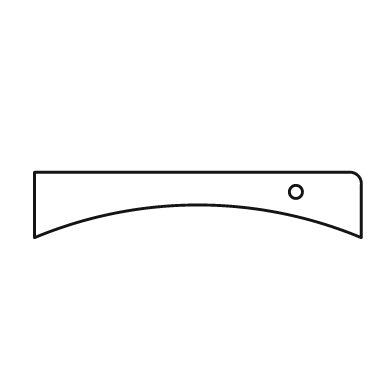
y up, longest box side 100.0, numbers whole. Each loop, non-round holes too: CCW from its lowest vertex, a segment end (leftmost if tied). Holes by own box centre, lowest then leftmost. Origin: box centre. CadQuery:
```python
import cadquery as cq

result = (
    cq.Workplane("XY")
    .moveTo(-50.0, -10.0)
    .threePointArc((0.0, 0.0), (50.0, -10.0))
    .lineTo(50.0, 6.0)
    .threePointArc((49.0, 9.0), (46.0, 10.0))
    .lineTo(-50.0, 10.0)
    .close()
    .moveTo(30.0, 4.0)
    .circle(2.0)
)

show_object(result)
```